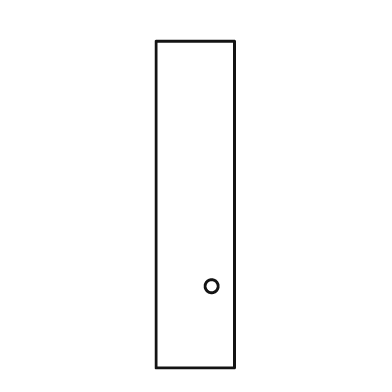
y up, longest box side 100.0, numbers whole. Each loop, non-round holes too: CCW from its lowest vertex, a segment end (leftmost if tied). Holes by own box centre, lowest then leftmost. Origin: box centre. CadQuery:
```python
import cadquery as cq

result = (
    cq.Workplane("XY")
    .moveTo(-12.0, -50.0)
    .lineTo(12.0, -50.0)
    .lineTo(12.0, 50.0)
    .lineTo(-12.0, 50.0)
    .close()
    .moveTo(5.0, -25.0)
    .circle(2.0)
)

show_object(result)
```